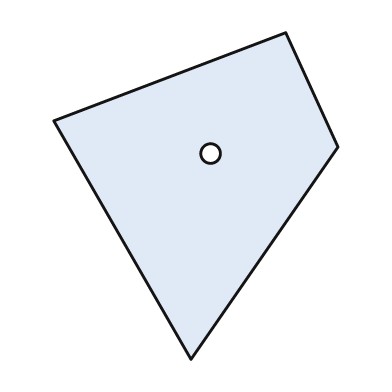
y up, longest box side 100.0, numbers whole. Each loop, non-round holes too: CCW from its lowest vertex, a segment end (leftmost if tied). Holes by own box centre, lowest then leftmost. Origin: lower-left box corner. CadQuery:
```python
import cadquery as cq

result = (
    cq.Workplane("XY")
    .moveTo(42.0, 0.0)
    .lineTo(87.0, 65.0)
    .lineTo(71.0, 100.0)
    .lineTo(0.0, 73.0)
    .close()
    .moveTo(48.0, 63.0)
    .circle(3.0)
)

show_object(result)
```